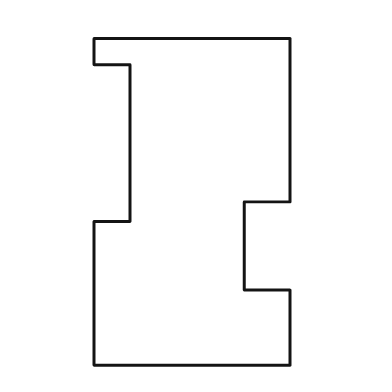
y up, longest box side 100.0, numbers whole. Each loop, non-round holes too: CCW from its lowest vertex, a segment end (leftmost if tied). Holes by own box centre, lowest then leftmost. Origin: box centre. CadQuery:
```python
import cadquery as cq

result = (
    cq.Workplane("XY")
    .moveTo(-30.0, -50.0)
    .lineTo(30.0, -50.0)
    .lineTo(30.0, -27.0)
    .lineTo(16.0, -27.0)
    .lineTo(16.0, 0.0)
    .lineTo(30.0, 0.0)
    .lineTo(30.0, 50.0)
    .lineTo(-30.0, 50.0)
    .lineTo(-30.0, 42.0)
    .lineTo(-19.0, 42.0)
    .lineTo(-19.0, -6.0)
    .lineTo(-30.0, -6.0)
    .close()
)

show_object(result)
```